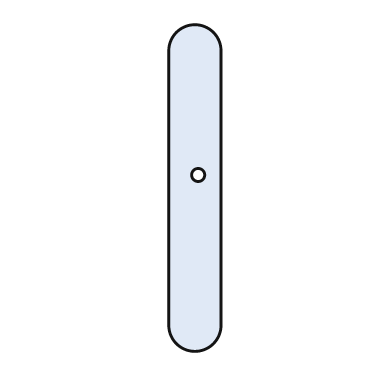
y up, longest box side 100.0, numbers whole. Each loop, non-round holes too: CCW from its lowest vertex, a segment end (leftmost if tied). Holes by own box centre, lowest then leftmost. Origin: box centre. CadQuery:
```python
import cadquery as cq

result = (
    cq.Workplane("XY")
    .moveTo(-8.0, -42.0)
    .threePointArc((0.0, -50.0), (8.0, -42.0))
    .lineTo(8.0, 42.0)
    .threePointArc((0.0, 50.0), (-8.0, 42.0))
    .close()
    .moveTo(1.0, 4.0)
    .circle(2.0)
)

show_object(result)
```